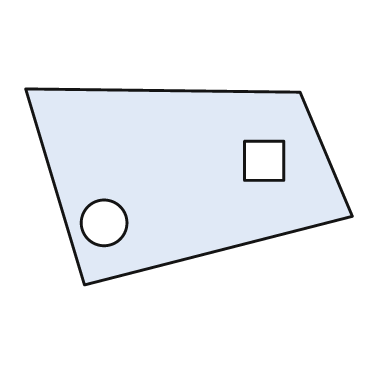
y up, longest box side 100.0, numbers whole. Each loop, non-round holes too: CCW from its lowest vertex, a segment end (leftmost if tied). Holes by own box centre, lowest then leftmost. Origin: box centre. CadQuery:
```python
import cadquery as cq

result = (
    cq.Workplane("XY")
    .moveTo(-32.0, -30.0)
    .lineTo(50.0, -9.0)
    .lineTo(34.0, 29.0)
    .lineTo(-50.0, 30.0)
    .close()
    .moveTo(-26.0, -11.0)
    .circle(7.0)
    .moveTo(17.0, 2.0)
    .lineTo(29.0, 2.0)
    .lineTo(29.0, 14.0)
    .lineTo(17.0, 14.0)
    .close()
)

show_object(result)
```